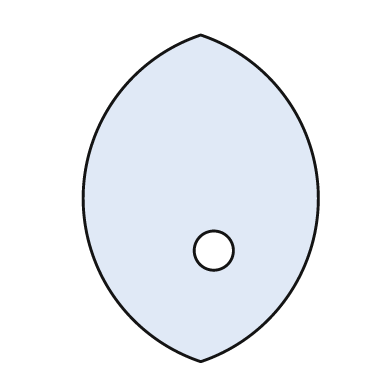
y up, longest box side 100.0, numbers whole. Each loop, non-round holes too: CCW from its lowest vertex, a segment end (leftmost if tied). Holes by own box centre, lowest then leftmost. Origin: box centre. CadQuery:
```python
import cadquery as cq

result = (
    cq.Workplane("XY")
    .moveTo(0.0, -50.0)
    .threePointArc((36.0, 0.0), (0.0, 50.0))
    .threePointArc((-36.0, 0.0), (0.0, -50.0))
    .close()
    .moveTo(4.0, -16.0)
    .circle(6.0)
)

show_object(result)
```